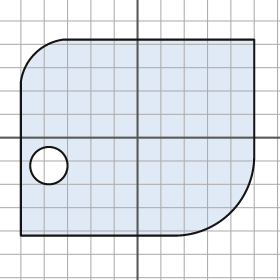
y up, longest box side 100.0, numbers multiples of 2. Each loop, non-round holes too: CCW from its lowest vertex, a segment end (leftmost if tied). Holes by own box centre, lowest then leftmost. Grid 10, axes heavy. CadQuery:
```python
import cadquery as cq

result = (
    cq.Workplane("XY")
    .moveTo(-50.0, -42.0)
    .lineTo(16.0, -42.0)
    .threePointArc((40.0, -32.0), (50.0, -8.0))
    .lineTo(50.0, 42.0)
    .lineTo(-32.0, 42.0)
    .threePointArc((-44.0, 36.0), (-50.0, 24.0))
    .close()
    .moveTo(-38.0, -12.0)
    .circle(8.0)
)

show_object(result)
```